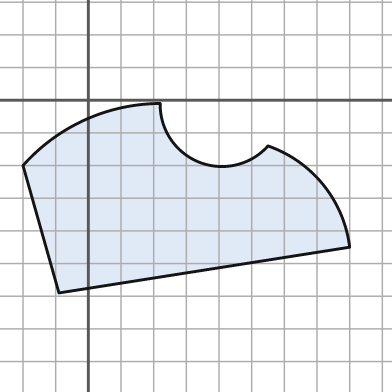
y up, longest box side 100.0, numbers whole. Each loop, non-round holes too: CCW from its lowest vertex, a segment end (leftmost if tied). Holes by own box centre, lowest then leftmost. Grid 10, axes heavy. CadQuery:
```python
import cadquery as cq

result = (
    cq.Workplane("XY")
    .moveTo(-9.0, -59.0)
    .lineTo(80.0, -45.0)
    .threePointArc((72.0, -26.0), (55.0, -14.0))
    .threePointArc((34.0, -19.0), (22.0, -1.0))
    .threePointArc((-1.0, -6.0), (-20.0, -20.0))
    .close()
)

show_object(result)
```